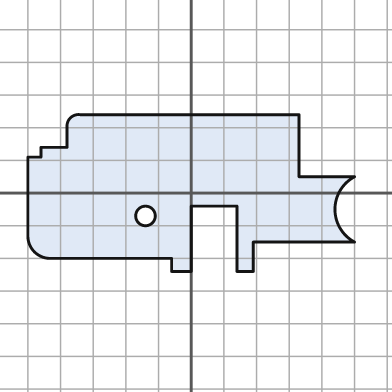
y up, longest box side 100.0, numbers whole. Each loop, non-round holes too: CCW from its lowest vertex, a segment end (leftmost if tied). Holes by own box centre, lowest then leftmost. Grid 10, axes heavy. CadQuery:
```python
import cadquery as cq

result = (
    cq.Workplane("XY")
    .moveTo(-6.0, -24.0)
    .lineTo(0.0, -24.0)
    .lineTo(0.0, -4.0)
    .lineTo(14.0, -4.0)
    .lineTo(14.0, -24.0)
    .lineTo(19.0, -24.0)
    .lineTo(19.0, -15.0)
    .lineTo(50.0, -15.0)
    .threePointArc((44.0, -5.0), (50.0, 5.0))
    .lineTo(33.0, 5.0)
    .lineTo(33.0, 24.0)
    .lineTo(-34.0, 24.0)
    .threePointArc((-37.0, 23.0), (-38.0, 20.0))
    .lineTo(-38.0, 14.0)
    .lineTo(-46.0, 14.0)
    .lineTo(-46.0, 11.0)
    .lineTo(-50.0, 11.0)
    .lineTo(-50.0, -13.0)
    .threePointArc((-48.0, -18.0), (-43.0, -20.0))
    .lineTo(-6.0, -20.0)
    .close()
    .moveTo(-14.0, -7.0)
    .circle(3.0)
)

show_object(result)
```